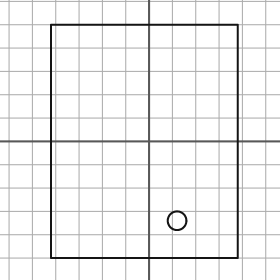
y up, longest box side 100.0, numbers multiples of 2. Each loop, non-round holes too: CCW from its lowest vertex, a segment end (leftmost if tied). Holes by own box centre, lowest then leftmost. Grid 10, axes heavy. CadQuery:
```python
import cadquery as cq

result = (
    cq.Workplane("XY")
    .moveTo(-42.0, -50.0)
    .lineTo(38.0, -50.0)
    .lineTo(38.0, 50.0)
    .lineTo(-42.0, 50.0)
    .close()
    .moveTo(12.0, -34.0)
    .circle(4.0)
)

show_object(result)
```